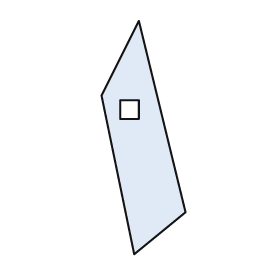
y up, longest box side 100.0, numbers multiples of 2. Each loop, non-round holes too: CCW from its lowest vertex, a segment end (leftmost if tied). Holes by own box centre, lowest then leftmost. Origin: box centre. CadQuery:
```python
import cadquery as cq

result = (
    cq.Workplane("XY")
    .moveTo(-4.0, -50.0)
    .lineTo(18.0, -32.0)
    .lineTo(-2.0, 50.0)
    .lineTo(-18.0, 18.0)
    .close()
    .moveTo(-10.0, 8.0)
    .lineTo(-2.0, 8.0)
    .lineTo(-2.0, 16.0)
    .lineTo(-10.0, 16.0)
    .close()
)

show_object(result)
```